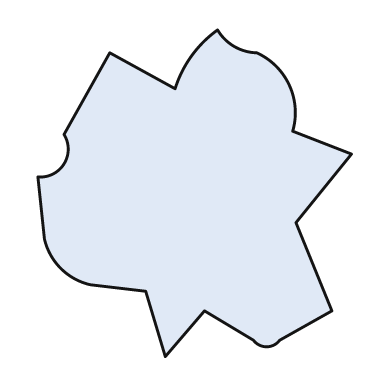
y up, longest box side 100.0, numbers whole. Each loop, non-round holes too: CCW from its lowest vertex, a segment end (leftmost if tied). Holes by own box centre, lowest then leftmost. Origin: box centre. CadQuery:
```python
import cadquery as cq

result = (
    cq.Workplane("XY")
    .moveTo(-9.0, -50.0)
    .lineTo(3.0, -36.0)
    .lineTo(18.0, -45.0)
    .threePointArc((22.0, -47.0), (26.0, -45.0))
    .lineTo(42.0, -36.0)
    .lineTo(31.0, -9.0)
    .lineTo(48.0, 12.0)
    .lineTo(30.0, 19.0)
    .threePointArc((29.0, 33.0), (19.0, 43.0))
    .threePointArc((12.0, 45.0), (7.0, 50.0))
    .threePointArc((-1.0, 42.0), (-6.0, 32.0))
    .lineTo(-26.0, 43.0)
    .lineTo(-40.0, 18.0)
    .threePointArc((-40.0, 9.0), (-48.0, 5.0))
    .lineTo(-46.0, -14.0)
    .threePointArc((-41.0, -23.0), (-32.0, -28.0))
    .lineTo(-15.0, -30.0)
    .close()
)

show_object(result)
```